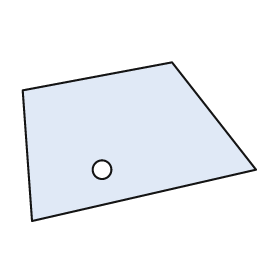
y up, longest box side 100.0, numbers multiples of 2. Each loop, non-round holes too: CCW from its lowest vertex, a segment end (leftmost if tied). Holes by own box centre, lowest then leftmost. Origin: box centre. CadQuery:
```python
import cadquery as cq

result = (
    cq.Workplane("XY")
    .moveTo(-46.0, -34.0)
    .lineTo(50.0, -12.0)
    .lineTo(14.0, 34.0)
    .lineTo(-50.0, 22.0)
    .close()
    .moveTo(-16.0, -12.0)
    .circle(4.0)
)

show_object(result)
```